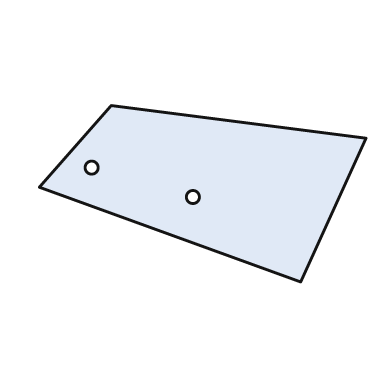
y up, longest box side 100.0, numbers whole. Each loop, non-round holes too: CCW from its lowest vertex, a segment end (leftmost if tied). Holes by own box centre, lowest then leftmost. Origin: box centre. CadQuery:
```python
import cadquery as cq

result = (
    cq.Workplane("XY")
    .moveTo(30.0, -27.0)
    .lineTo(50.0, 17.0)
    .lineTo(-28.0, 27.0)
    .lineTo(-50.0, 2.0)
    .close()
    .moveTo(-3.0, -1.0)
    .circle(2.0)
    .moveTo(-34.0, 8.0)
    .circle(2.0)
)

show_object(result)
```